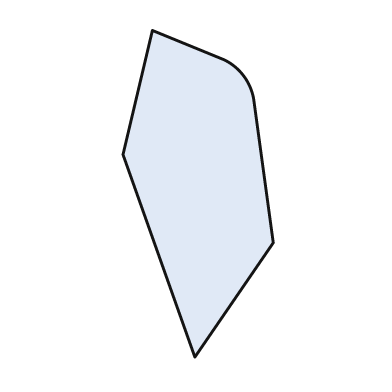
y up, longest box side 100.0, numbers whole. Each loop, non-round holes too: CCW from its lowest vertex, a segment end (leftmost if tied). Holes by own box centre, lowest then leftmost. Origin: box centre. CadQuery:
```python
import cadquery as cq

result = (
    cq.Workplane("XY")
    .moveTo(-1.0, -50.0)
    .lineTo(23.0, -15.0)
    .lineTo(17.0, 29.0)
    .threePointArc((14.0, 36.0), (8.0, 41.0))
    .lineTo(-14.0, 50.0)
    .lineTo(-23.0, 12.0)
    .close()
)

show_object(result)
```